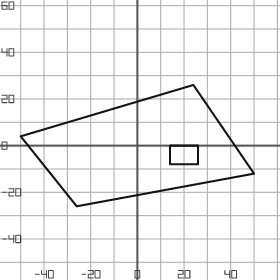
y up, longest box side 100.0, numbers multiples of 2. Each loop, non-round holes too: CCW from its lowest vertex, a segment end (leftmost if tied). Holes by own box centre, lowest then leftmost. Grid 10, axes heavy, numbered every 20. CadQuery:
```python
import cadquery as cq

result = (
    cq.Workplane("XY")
    .moveTo(-26.0, -26.0)
    .lineTo(50.0, -12.0)
    .lineTo(24.0, 26.0)
    .lineTo(-50.0, 4.0)
    .close()
    .moveTo(14.0, -8.0)
    .lineTo(26.0, -8.0)
    .lineTo(26.0, 0.0)
    .lineTo(14.0, 0.0)
    .close()
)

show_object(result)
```